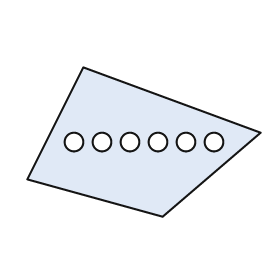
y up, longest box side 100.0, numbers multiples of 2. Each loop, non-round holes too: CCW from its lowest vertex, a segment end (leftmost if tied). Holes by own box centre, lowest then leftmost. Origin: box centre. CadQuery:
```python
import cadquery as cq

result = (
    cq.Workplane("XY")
    .moveTo(8.0, -32.0)
    .lineTo(50.0, 4.0)
    .lineTo(-26.0, 32.0)
    .lineTo(-50.0, -16.0)
    .close()
    .moveTo(-30.0, 0.0)
    .circle(4.0)
    .moveTo(-18.0, 0.0)
    .circle(4.0)
    .moveTo(-6.0, 0.0)
    .circle(4.0)
    .moveTo(6.0, 0.0)
    .circle(4.0)
    .moveTo(18.0, 0.0)
    .circle(4.0)
    .moveTo(30.0, 0.0)
    .circle(4.0)
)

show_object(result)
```